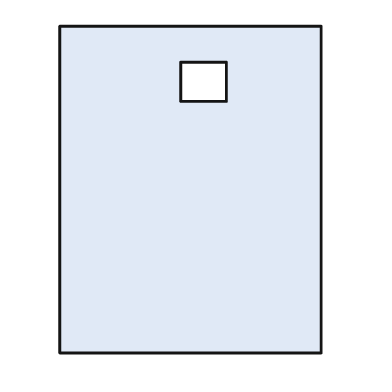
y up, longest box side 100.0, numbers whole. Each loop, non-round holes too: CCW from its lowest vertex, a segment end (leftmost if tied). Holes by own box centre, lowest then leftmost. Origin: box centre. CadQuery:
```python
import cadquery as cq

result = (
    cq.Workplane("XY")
    .moveTo(-40.0, -50.0)
    .lineTo(40.0, -50.0)
    .lineTo(40.0, 50.0)
    .lineTo(-40.0, 50.0)
    .close()
    .moveTo(-3.0, 27.0)
    .lineTo(11.0, 27.0)
    .lineTo(11.0, 39.0)
    .lineTo(-3.0, 39.0)
    .close()
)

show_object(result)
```